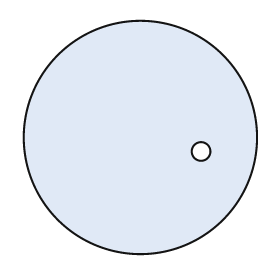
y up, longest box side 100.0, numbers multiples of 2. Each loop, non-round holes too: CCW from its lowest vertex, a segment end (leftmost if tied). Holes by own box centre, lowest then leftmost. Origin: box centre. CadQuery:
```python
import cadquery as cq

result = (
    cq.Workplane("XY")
    .moveTo(0.0, 0.0)
    .circle(50.0)
    .moveTo(26.0, -6.0)
    .circle(4.0)
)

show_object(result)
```